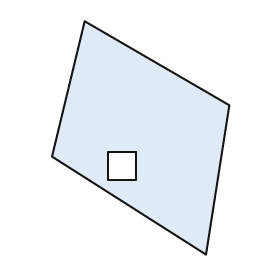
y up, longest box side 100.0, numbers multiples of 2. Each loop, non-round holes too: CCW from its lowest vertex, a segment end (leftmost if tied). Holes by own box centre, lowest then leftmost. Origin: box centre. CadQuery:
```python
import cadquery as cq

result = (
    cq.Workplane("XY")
    .moveTo(28.0, -50.0)
    .lineTo(38.0, 14.0)
    .lineTo(-24.0, 50.0)
    .lineTo(-38.0, -8.0)
    .close()
    .moveTo(-14.0, -18.0)
    .lineTo(-2.0, -18.0)
    .lineTo(-2.0, -6.0)
    .lineTo(-14.0, -6.0)
    .close()
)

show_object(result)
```